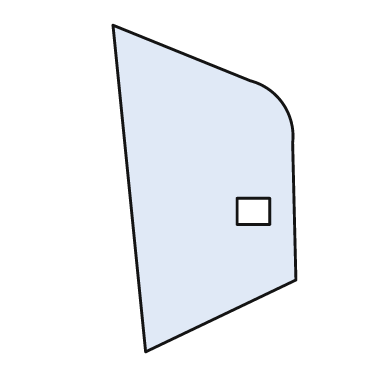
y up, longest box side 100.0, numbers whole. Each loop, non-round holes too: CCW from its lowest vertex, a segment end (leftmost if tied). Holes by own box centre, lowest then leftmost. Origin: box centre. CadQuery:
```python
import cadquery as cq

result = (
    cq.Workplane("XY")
    .moveTo(-18.0, -50.0)
    .lineTo(28.0, -28.0)
    .lineTo(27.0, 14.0)
    .threePointArc((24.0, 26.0), (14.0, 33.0))
    .lineTo(-28.0, 50.0)
    .close()
    .moveTo(10.0, -11.0)
    .lineTo(20.0, -11.0)
    .lineTo(20.0, -3.0)
    .lineTo(10.0, -3.0)
    .close()
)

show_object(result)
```